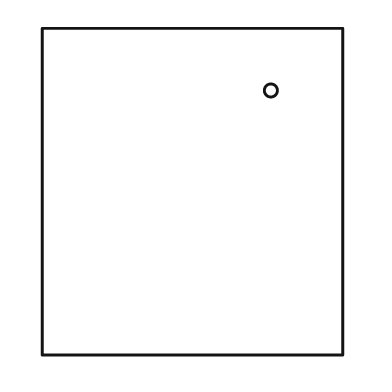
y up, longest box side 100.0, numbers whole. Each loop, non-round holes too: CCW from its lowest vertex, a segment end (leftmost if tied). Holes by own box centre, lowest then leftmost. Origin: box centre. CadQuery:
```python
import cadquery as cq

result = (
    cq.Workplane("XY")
    .moveTo(-46.0, -50.0)
    .lineTo(46.0, -50.0)
    .lineTo(46.0, 50.0)
    .lineTo(-46.0, 50.0)
    .close()
    .moveTo(24.0, 31.0)
    .circle(2.0)
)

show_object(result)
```